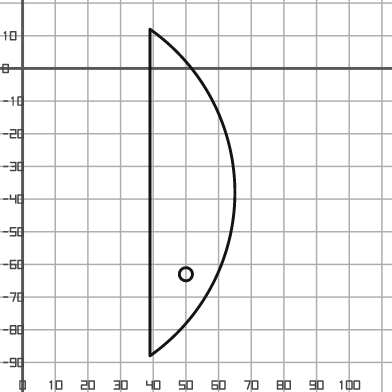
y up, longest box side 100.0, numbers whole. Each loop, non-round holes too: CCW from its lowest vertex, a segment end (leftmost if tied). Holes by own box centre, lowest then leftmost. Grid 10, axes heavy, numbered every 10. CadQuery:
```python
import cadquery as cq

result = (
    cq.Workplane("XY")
    .moveTo(39.0, -88.0)
    .threePointArc((65.0, -38.0), (39.0, 12.0))
    .close()
    .moveTo(50.0, -63.0)
    .circle(2.0)
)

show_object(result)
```